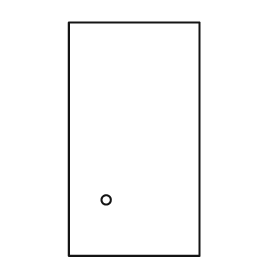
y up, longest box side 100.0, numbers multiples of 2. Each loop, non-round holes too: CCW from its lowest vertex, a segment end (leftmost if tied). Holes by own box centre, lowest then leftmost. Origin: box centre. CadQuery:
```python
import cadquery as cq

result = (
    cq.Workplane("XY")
    .moveTo(-28.0, -50.0)
    .lineTo(28.0, -50.0)
    .lineTo(28.0, 50.0)
    .lineTo(-28.0, 50.0)
    .close()
    .moveTo(-12.0, -26.0)
    .circle(2.0)
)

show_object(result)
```